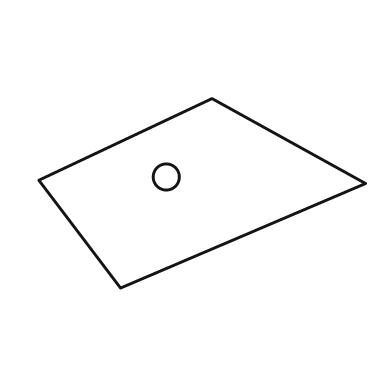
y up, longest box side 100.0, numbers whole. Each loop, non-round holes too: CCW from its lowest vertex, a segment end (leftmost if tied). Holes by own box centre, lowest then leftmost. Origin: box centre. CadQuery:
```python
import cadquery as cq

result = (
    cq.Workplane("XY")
    .moveTo(-25.0, -29.0)
    .lineTo(50.0, 3.0)
    .lineTo(3.0, 29.0)
    .lineTo(-50.0, 4.0)
    .close()
    .moveTo(-11.0, 5.0)
    .circle(4.0)
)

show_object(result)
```